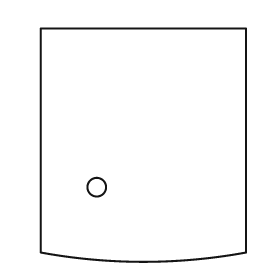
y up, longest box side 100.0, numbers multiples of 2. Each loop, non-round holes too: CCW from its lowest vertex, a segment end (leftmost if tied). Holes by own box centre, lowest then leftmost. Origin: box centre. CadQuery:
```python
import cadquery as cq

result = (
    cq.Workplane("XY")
    .moveTo(-44.0, -46.0)
    .threePointArc((0.0, -50.0), (44.0, -46.0))
    .lineTo(44.0, 50.0)
    .lineTo(-44.0, 50.0)
    .close()
    .moveTo(-20.0, -18.0)
    .circle(4.0)
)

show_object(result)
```